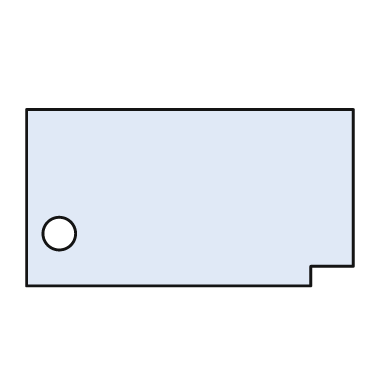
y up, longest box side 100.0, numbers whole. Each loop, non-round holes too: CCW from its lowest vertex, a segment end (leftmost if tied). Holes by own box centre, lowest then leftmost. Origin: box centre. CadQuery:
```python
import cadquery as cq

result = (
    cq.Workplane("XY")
    .moveTo(-50.0, -27.0)
    .lineTo(37.0, -27.0)
    .lineTo(37.0, -21.0)
    .lineTo(50.0, -21.0)
    .lineTo(50.0, 27.0)
    .lineTo(-50.0, 27.0)
    .close()
    .moveTo(-40.0, -11.0)
    .circle(5.0)
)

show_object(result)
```